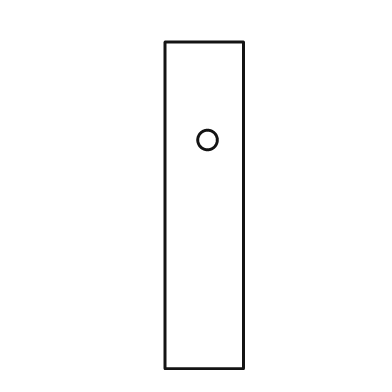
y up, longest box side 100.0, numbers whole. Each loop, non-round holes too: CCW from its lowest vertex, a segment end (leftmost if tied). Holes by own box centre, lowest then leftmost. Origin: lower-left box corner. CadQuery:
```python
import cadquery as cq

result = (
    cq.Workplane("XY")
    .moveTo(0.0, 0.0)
    .lineTo(24.0, 0.0)
    .lineTo(24.0, 100.0)
    .lineTo(0.0, 100.0)
    .close()
    .moveTo(13.0, 70.0)
    .circle(3.0)
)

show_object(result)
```